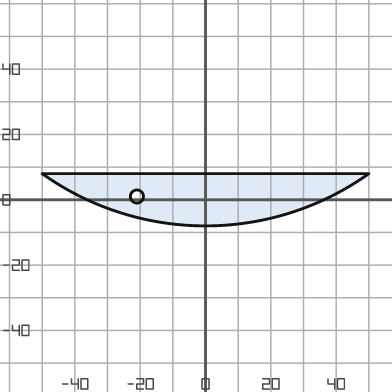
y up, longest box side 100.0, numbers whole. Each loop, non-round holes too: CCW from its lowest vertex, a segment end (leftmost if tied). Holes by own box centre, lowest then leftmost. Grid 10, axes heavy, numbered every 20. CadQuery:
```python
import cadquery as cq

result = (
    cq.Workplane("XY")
    .moveTo(-50.0, 8.0)
    .threePointArc((0.0, -8.0), (50.0, 8.0))
    .close()
    .moveTo(-21.0, 1.0)
    .circle(2.0)
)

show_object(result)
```